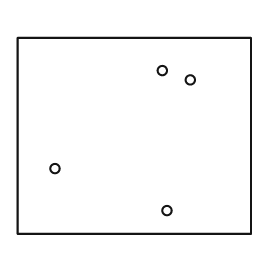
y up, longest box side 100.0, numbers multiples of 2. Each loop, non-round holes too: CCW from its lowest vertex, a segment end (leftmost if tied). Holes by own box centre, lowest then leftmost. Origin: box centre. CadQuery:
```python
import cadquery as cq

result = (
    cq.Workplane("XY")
    .moveTo(-50.0, -42.0)
    .lineTo(50.0, -42.0)
    .lineTo(50.0, 42.0)
    .lineTo(-50.0, 42.0)
    .close()
    .moveTo(14.0, -32.0)
    .circle(2.0)
    .moveTo(-34.0, -14.0)
    .circle(2.0)
    .moveTo(24.0, 24.0)
    .circle(2.0)
    .moveTo(12.0, 28.0)
    .circle(2.0)
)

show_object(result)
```